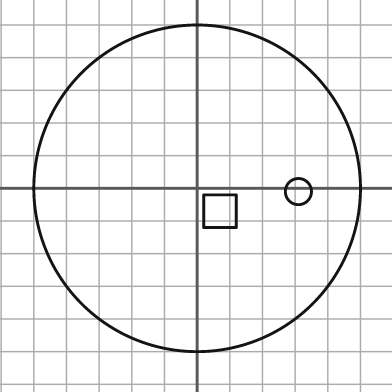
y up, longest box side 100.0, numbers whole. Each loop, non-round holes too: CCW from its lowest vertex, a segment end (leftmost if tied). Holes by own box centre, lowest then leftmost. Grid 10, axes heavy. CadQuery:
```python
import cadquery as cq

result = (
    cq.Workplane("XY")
    .moveTo(0.0, 0.0)
    .circle(50.0)
    .moveTo(2.0, -12.0)
    .lineTo(12.0, -12.0)
    .lineTo(12.0, -2.0)
    .lineTo(2.0, -2.0)
    .close()
    .moveTo(31.0, -1.0)
    .circle(4.0)
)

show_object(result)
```